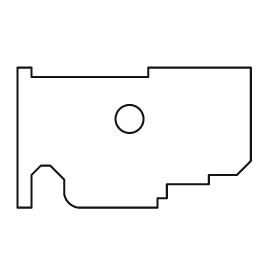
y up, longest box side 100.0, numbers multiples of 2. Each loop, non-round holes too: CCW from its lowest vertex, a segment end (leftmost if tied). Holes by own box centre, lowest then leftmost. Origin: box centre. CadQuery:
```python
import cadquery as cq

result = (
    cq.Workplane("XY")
    .moveTo(-50.0, -30.0)
    .lineTo(-44.0, -30.0)
    .lineTo(-44.0, -16.0)
    .lineTo(-40.0, -12.0)
    .lineTo(-36.0, -12.0)
    .lineTo(-30.0, -18.0)
    .lineTo(-30.0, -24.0)
    .threePointArc((-28.0, -28.0), (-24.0, -30.0))
    .lineTo(10.0, -30.0)
    .lineTo(10.0, -26.0)
    .lineTo(14.0, -26.0)
    .lineTo(14.0, -20.0)
    .lineTo(32.0, -20.0)
    .lineTo(32.0, -16.0)
    .lineTo(44.0, -16.0)
    .lineTo(50.0, -10.0)
    .lineTo(50.0, 30.0)
    .lineTo(6.0, 30.0)
    .lineTo(6.0, 26.0)
    .lineTo(-44.0, 26.0)
    .lineTo(-44.0, 30.0)
    .lineTo(-50.0, 30.0)
    .close()
    .moveTo(-2.0, 8.0)
    .circle(6.0)
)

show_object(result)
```